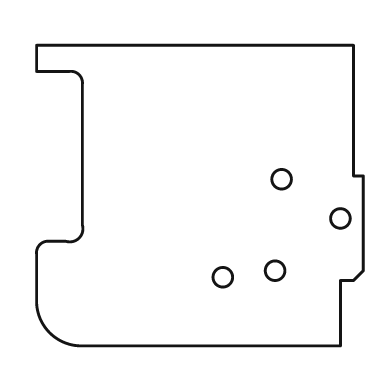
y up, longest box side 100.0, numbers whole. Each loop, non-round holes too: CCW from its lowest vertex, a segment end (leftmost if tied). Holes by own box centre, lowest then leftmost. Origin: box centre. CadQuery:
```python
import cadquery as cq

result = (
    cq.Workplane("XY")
    .moveTo(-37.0, -46.0)
    .lineTo(43.0, -46.0)
    .lineTo(43.0, -26.0)
    .lineTo(47.0, -26.0)
    .lineTo(50.0, -23.0)
    .lineTo(50.0, 6.0)
    .lineTo(47.0, 6.0)
    .lineTo(47.0, 46.0)
    .lineTo(-50.0, 46.0)
    .lineTo(-50.0, 38.0)
    .lineTo(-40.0, 38.0)
    .threePointArc((-37.0, 37.0), (-36.0, 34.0))
    .lineTo(-36.0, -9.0)
    .threePointArc((-37.0, -13.0), (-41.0, -14.0))
    .lineTo(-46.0, -14.0)
    .threePointArc((-49.0, -15.0), (-50.0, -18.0))
    .lineTo(-50.0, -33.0)
    .threePointArc((-46.0, -42.0), (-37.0, -46.0))
    .close()
    .moveTo(7.0, -25.0)
    .circle(3.0)
    .moveTo(23.0, -23.0)
    .circle(3.0)
    .moveTo(43.0, -7.0)
    .circle(3.0)
    .moveTo(25.0, 5.0)
    .circle(3.0)
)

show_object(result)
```